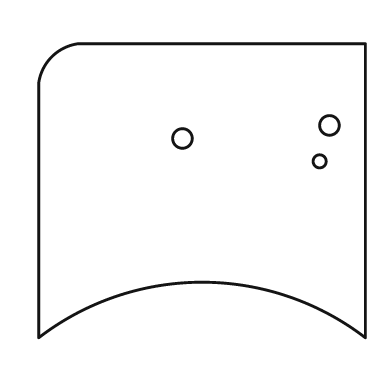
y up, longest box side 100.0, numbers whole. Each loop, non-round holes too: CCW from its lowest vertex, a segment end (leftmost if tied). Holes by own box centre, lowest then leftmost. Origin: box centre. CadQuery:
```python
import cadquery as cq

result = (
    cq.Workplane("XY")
    .moveTo(-50.0, -45.0)
    .threePointArc((0.0, -28.0), (50.0, -45.0))
    .lineTo(50.0, 45.0)
    .lineTo(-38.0, 45.0)
    .threePointArc((-46.0, 41.0), (-50.0, 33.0))
    .close()
    .moveTo(36.0, 9.0)
    .circle(2.0)
    .moveTo(-6.0, 16.0)
    .circle(3.0)
    .moveTo(39.0, 20.0)
    .circle(3.0)
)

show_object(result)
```